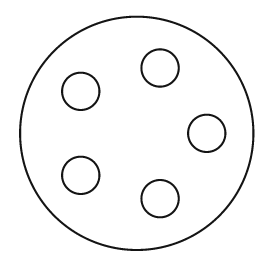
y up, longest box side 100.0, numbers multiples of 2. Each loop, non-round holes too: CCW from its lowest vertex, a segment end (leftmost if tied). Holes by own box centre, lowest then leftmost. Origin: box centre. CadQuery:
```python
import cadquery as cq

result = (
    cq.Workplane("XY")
    .moveTo(0.0, 0.0)
    .circle(50.0)
    .moveTo(10.0, -28.0)
    .circle(8.0)
    .moveTo(-24.0, -18.0)
    .circle(8.0)
    .moveTo(30.0, 0.0)
    .circle(8.0)
    .moveTo(-24.0, 18.0)
    .circle(8.0)
    .moveTo(10.0, 28.0)
    .circle(8.0)
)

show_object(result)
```